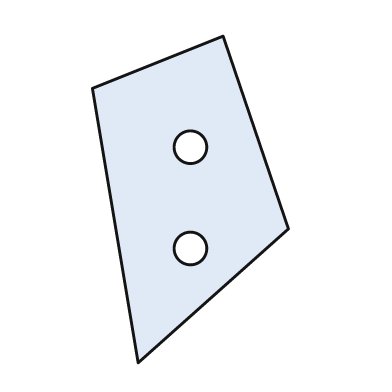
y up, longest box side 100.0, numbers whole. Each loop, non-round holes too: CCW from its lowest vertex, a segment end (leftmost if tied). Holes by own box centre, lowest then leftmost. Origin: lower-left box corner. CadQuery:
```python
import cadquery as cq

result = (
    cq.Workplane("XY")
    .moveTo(14.0, 0.0)
    .lineTo(60.0, 41.0)
    .lineTo(40.0, 100.0)
    .lineTo(0.0, 84.0)
    .close()
    .moveTo(30.0, 35.0)
    .circle(5.0)
    .moveTo(30.0, 66.0)
    .circle(5.0)
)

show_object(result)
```